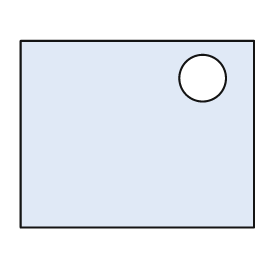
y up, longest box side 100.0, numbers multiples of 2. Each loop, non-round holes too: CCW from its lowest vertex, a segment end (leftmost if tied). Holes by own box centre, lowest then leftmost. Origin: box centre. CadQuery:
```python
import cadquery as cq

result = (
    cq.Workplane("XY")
    .moveTo(-50.0, -40.0)
    .lineTo(50.0, -40.0)
    .lineTo(50.0, 40.0)
    .lineTo(-50.0, 40.0)
    .close()
    .moveTo(28.0, 24.0)
    .circle(10.0)
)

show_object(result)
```